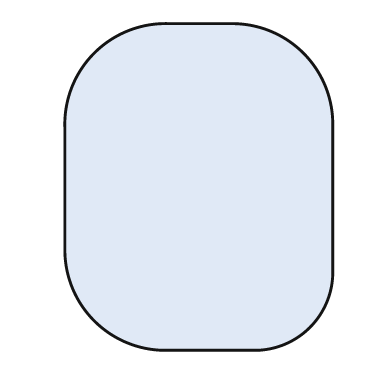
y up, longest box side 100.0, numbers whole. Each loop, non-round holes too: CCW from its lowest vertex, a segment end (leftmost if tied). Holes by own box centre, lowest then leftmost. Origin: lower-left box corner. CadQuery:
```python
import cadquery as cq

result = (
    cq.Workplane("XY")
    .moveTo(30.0, 0.0)
    .lineTo(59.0, 0.0)
    .threePointArc((75.0, 7.0), (82.0, 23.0))
    .lineTo(82.0, 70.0)
    .threePointArc((73.0, 91.0), (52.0, 100.0))
    .lineTo(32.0, 100.0)
    .threePointArc((9.0, 91.0), (0.0, 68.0))
    .lineTo(0.0, 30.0)
    .threePointArc((9.0, 9.0), (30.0, 0.0))
    .close()
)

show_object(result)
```